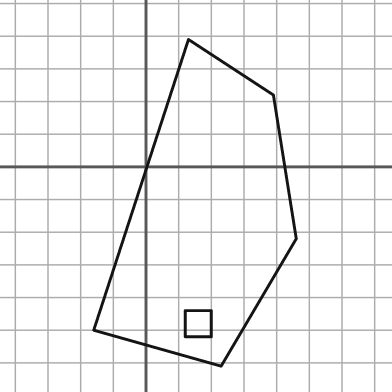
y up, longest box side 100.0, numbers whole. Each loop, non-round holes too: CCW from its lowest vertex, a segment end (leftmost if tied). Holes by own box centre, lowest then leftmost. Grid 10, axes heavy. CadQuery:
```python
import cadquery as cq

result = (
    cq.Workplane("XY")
    .moveTo(23.0, -61.0)
    .lineTo(46.0, -22.0)
    .lineTo(39.0, 22.0)
    .lineTo(13.0, 39.0)
    .lineTo(-16.0, -50.0)
    .close()
    .moveTo(12.0, -52.0)
    .lineTo(20.0, -52.0)
    .lineTo(20.0, -44.0)
    .lineTo(12.0, -44.0)
    .close()
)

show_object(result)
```